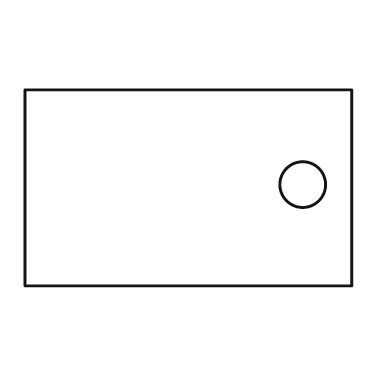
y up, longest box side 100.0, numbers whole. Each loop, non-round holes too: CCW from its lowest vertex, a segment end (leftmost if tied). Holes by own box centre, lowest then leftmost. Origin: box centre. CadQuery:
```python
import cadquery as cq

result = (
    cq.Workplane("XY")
    .moveTo(-50.0, -30.0)
    .lineTo(50.0, -30.0)
    .lineTo(50.0, 30.0)
    .lineTo(-50.0, 30.0)
    .close()
    .moveTo(35.0, 1.0)
    .circle(7.0)
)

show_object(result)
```